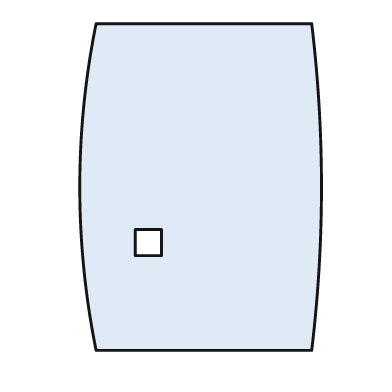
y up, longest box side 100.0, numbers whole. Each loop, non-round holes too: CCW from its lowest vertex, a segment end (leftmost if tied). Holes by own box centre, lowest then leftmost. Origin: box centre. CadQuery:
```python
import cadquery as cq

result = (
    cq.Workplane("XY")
    .moveTo(-32.0, -50.0)
    .lineTo(34.0, -50.0)
    .threePointArc((37.0, 0.0), (34.0, 50.0))
    .lineTo(-32.0, 50.0)
    .threePointArc((-37.0, 0.0), (-32.0, -50.0))
    .close()
    .moveTo(-20.0, -21.0)
    .lineTo(-12.0, -21.0)
    .lineTo(-12.0, -13.0)
    .lineTo(-20.0, -13.0)
    .close()
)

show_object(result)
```